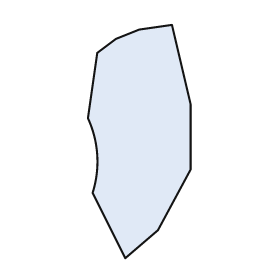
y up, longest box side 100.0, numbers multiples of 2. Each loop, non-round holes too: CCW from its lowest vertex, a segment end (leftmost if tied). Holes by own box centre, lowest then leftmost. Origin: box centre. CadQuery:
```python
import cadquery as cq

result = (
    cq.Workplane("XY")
    .moveTo(-6.0, -50.0)
    .lineTo(8.0, -38.0)
    .lineTo(22.0, -12.0)
    .lineTo(22.0, 16.0)
    .lineTo(14.0, 50.0)
    .lineTo(0.0, 48.0)
    .lineTo(-10.0, 44.0)
    .lineTo(-18.0, 38.0)
    .lineTo(-22.0, 10.0)
    .threePointArc((-18.0, -6.0), (-20.0, -22.0))
    .close()
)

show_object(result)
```